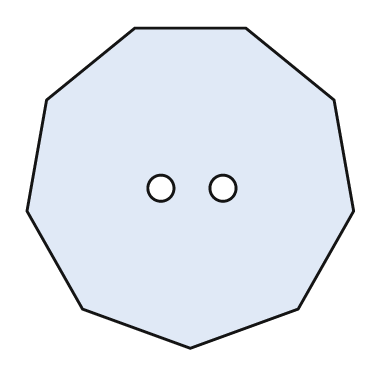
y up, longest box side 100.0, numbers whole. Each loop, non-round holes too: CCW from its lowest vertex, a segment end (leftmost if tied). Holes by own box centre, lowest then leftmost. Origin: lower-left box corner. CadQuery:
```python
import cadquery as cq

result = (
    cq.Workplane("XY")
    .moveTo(50.0, 0.0)
    .lineTo(83.0, 12.0)
    .lineTo(100.0, 42.0)
    .lineTo(94.0, 76.0)
    .lineTo(67.0, 98.0)
    .lineTo(33.0, 98.0)
    .lineTo(6.0, 76.0)
    .lineTo(0.0, 42.0)
    .lineTo(17.0, 12.0)
    .close()
    .moveTo(41.0, 49.0)
    .circle(4.0)
    .moveTo(60.0, 49.0)
    .circle(4.0)
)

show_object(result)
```